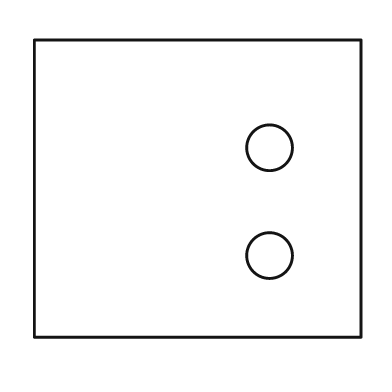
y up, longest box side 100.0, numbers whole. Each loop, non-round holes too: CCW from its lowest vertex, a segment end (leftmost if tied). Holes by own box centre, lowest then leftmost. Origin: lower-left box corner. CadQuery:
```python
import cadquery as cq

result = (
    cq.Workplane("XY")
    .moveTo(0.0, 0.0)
    .lineTo(100.0, 0.0)
    .lineTo(100.0, 91.0)
    .lineTo(0.0, 91.0)
    .close()
    .moveTo(72.0, 25.0)
    .circle(7.0)
    .moveTo(72.0, 58.0)
    .circle(7.0)
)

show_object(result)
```